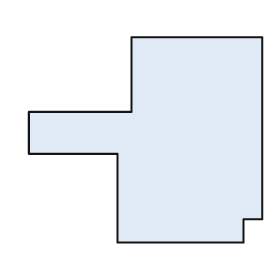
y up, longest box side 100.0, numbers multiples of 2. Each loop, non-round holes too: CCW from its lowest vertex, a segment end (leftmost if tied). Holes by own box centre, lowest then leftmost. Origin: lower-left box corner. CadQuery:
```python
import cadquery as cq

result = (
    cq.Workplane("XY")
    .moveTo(38.0, 0.0)
    .lineTo(92.0, 0.0)
    .lineTo(92.0, 10.0)
    .lineTo(100.0, 10.0)
    .lineTo(100.0, 88.0)
    .lineTo(44.0, 88.0)
    .lineTo(44.0, 56.0)
    .lineTo(0.0, 56.0)
    .lineTo(0.0, 38.0)
    .lineTo(38.0, 38.0)
    .close()
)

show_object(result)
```